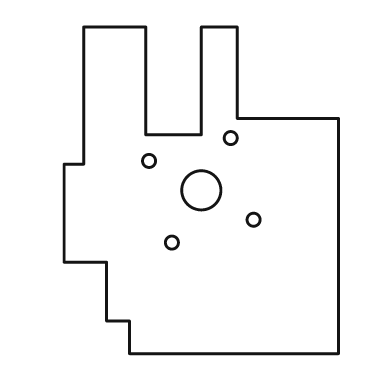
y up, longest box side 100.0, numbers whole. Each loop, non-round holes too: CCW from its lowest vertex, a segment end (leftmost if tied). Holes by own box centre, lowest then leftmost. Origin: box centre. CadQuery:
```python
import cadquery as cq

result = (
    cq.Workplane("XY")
    .moveTo(-22.0, -50.0)
    .lineTo(42.0, -50.0)
    .lineTo(42.0, 22.0)
    .lineTo(11.0, 22.0)
    .lineTo(11.0, 50.0)
    .lineTo(0.0, 50.0)
    .lineTo(0.0, 17.0)
    .lineTo(-17.0, 17.0)
    .lineTo(-17.0, 50.0)
    .lineTo(-36.0, 50.0)
    .lineTo(-36.0, 8.0)
    .lineTo(-42.0, 8.0)
    .lineTo(-42.0, -22.0)
    .lineTo(-29.0, -22.0)
    .lineTo(-29.0, -40.0)
    .lineTo(-22.0, -40.0)
    .close()
    .moveTo(-9.0, -16.0)
    .circle(2.0)
    .moveTo(16.0, -9.0)
    .circle(2.0)
    .moveTo(0.0, 0.0)
    .circle(6.0)
    .moveTo(-16.0, 9.0)
    .circle(2.0)
    .moveTo(9.0, 16.0)
    .circle(2.0)
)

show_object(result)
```